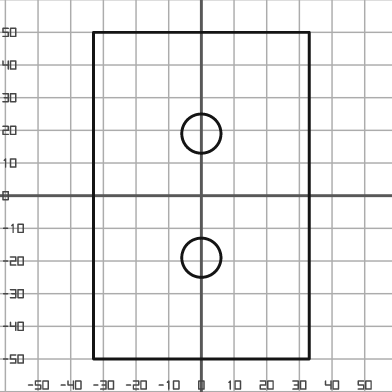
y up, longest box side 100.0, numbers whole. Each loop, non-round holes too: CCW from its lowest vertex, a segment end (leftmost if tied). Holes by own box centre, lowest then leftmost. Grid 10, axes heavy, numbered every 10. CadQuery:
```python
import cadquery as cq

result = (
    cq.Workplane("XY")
    .moveTo(-33.0, -50.0)
    .lineTo(33.0, -50.0)
    .lineTo(33.0, 50.0)
    .lineTo(-33.0, 50.0)
    .close()
    .moveTo(0.0, -19.0)
    .circle(6.0)
    .moveTo(0.0, 19.0)
    .circle(6.0)
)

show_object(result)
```